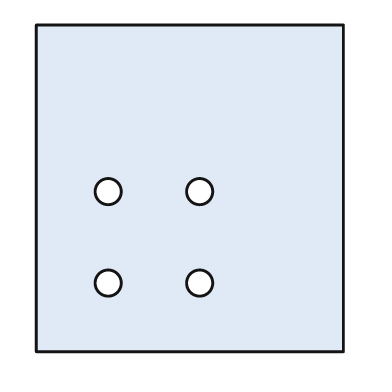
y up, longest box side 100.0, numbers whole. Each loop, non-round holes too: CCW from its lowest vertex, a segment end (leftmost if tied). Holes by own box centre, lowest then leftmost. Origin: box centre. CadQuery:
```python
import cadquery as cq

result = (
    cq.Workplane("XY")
    .moveTo(-47.0, -50.0)
    .lineTo(47.0, -50.0)
    .lineTo(47.0, 50.0)
    .lineTo(-47.0, 50.0)
    .close()
    .moveTo(-25.0, -29.0)
    .circle(4.0)
    .moveTo(3.0, -29.0)
    .circle(4.0)
    .moveTo(-25.0, -1.0)
    .circle(4.0)
    .moveTo(3.0, -1.0)
    .circle(4.0)
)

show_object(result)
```